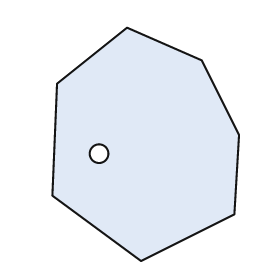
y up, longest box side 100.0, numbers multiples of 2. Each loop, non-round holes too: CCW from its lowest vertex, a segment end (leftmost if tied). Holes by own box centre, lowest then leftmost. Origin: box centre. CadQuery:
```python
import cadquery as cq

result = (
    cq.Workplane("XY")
    .moveTo(-2.0, -50.0)
    .lineTo(38.0, -30.0)
    .lineTo(40.0, 4.0)
    .lineTo(24.0, 36.0)
    .lineTo(-8.0, 50.0)
    .lineTo(-38.0, 26.0)
    .lineTo(-40.0, -22.0)
    .close()
    .moveTo(-20.0, -4.0)
    .circle(4.0)
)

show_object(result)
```